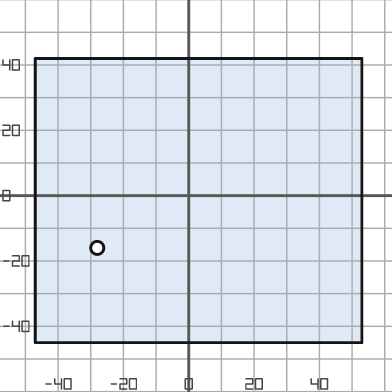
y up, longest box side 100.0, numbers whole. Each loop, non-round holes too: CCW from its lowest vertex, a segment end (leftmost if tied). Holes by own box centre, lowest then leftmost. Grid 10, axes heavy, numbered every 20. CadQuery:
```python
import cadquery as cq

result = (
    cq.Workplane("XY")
    .moveTo(-47.0, -45.0)
    .lineTo(53.0, -45.0)
    .lineTo(53.0, 42.0)
    .lineTo(-47.0, 42.0)
    .close()
    .moveTo(-28.0, -16.0)
    .circle(2.0)
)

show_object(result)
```